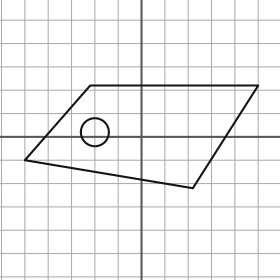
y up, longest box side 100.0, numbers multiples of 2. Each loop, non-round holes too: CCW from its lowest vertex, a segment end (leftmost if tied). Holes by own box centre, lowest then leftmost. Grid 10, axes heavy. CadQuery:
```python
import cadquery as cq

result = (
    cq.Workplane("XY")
    .moveTo(22.0, -22.0)
    .lineTo(50.0, 22.0)
    .lineTo(-22.0, 22.0)
    .lineTo(-50.0, -10.0)
    .close()
    .moveTo(-20.0, 2.0)
    .circle(6.0)
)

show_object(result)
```